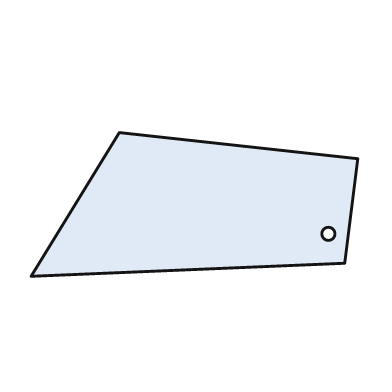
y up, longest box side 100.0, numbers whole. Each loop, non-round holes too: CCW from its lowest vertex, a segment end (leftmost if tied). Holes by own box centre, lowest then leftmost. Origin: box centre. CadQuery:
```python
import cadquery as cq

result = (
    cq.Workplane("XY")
    .moveTo(-50.0, -22.0)
    .lineTo(46.0, -18.0)
    .lineTo(50.0, 14.0)
    .lineTo(-23.0, 22.0)
    .close()
    .moveTo(41.0, -9.0)
    .circle(2.0)
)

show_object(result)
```